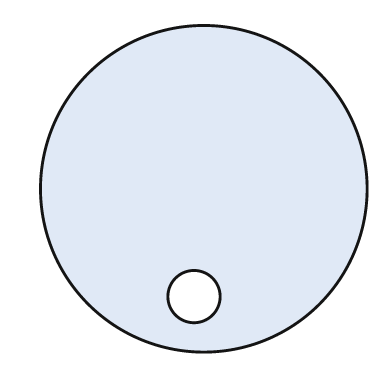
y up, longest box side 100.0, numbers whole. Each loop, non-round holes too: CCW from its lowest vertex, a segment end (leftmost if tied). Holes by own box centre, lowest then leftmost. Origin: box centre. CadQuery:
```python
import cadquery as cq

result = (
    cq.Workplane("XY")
    .moveTo(0.0, 0.0)
    .circle(50.0)
    .moveTo(-3.0, -33.0)
    .circle(8.0)
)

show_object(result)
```